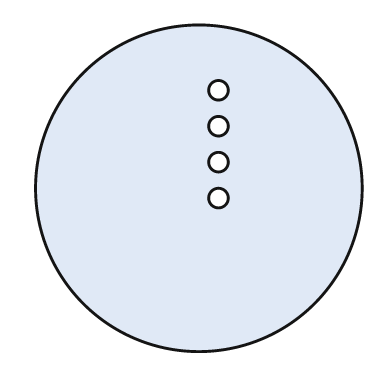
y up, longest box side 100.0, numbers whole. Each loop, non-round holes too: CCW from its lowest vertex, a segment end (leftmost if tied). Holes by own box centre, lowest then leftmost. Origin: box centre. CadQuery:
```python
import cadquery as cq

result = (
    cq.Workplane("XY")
    .moveTo(0.0, 0.0)
    .circle(50.0)
    .moveTo(6.0, -3.0)
    .circle(3.0)
    .moveTo(6.0, 8.0)
    .circle(3.0)
    .moveTo(6.0, 19.0)
    .circle(3.0)
    .moveTo(6.0, 30.0)
    .circle(3.0)
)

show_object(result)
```